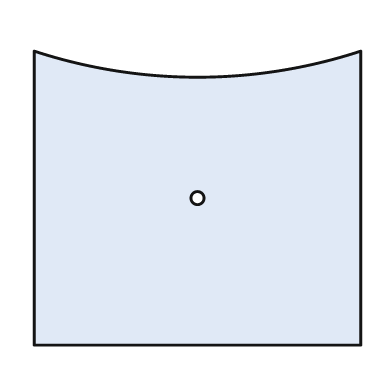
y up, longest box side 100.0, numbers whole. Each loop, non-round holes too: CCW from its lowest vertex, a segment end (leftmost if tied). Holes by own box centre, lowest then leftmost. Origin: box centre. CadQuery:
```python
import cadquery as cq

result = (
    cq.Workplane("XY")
    .moveTo(-50.0, -45.0)
    .lineTo(50.0, -45.0)
    .lineTo(50.0, 45.0)
    .threePointArc((0.0, 37.0), (-50.0, 45.0))
    .close()
    .moveTo(0.0, 0.0)
    .circle(2.0)
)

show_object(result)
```